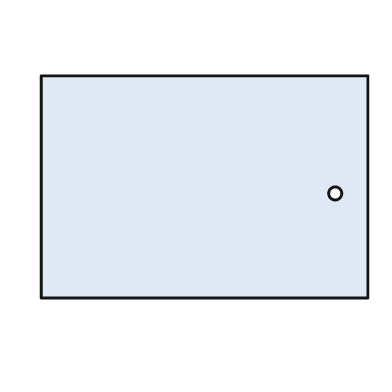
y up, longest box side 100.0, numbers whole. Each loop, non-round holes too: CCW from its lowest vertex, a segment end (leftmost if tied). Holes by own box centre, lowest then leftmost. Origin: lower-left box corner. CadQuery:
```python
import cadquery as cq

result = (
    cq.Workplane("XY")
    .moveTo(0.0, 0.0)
    .lineTo(100.0, 0.0)
    .lineTo(100.0, 68.0)
    .lineTo(0.0, 68.0)
    .close()
    .moveTo(90.0, 32.0)
    .circle(2.0)
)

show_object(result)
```